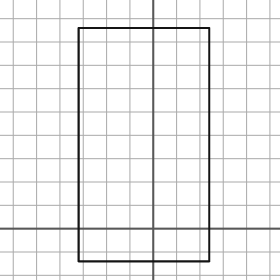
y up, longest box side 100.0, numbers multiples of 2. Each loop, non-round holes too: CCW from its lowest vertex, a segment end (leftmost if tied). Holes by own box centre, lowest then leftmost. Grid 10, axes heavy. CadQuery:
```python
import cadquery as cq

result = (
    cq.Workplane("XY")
    .moveTo(-32.0, -14.0)
    .lineTo(24.0, -14.0)
    .lineTo(24.0, 86.0)
    .lineTo(-32.0, 86.0)
    .close()
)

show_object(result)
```